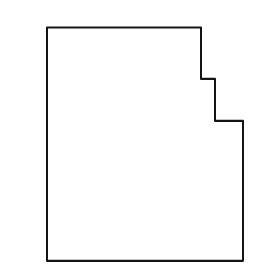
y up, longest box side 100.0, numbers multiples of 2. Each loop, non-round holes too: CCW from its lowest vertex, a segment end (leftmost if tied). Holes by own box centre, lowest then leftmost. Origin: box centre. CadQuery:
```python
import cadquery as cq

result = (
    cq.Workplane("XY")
    .moveTo(-42.0, -50.0)
    .lineTo(42.0, -50.0)
    .lineTo(42.0, 10.0)
    .lineTo(30.0, 10.0)
    .lineTo(30.0, 28.0)
    .lineTo(24.0, 28.0)
    .lineTo(24.0, 50.0)
    .lineTo(-42.0, 50.0)
    .close()
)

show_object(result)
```